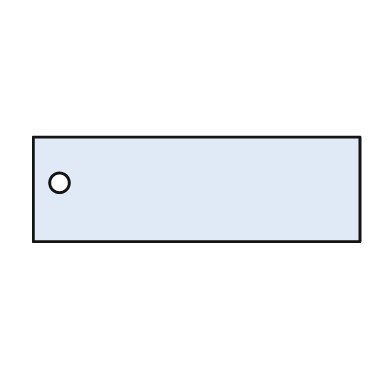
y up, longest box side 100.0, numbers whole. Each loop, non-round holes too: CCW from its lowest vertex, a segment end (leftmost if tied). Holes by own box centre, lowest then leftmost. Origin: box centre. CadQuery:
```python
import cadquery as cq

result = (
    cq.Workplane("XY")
    .moveTo(-50.0, -16.0)
    .lineTo(50.0, -16.0)
    .lineTo(50.0, 16.0)
    .lineTo(-50.0, 16.0)
    .close()
    .moveTo(-42.0, 2.0)
    .circle(3.0)
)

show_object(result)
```